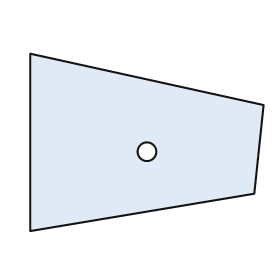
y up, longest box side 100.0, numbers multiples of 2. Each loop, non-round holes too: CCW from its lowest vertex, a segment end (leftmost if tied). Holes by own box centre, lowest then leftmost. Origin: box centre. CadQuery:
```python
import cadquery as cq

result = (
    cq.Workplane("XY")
    .moveTo(-50.0, -38.0)
    .lineTo(46.0, -22.0)
    .lineTo(50.0, 16.0)
    .lineTo(-50.0, 38.0)
    .close()
    .moveTo(0.0, -4.0)
    .circle(4.0)
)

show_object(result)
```